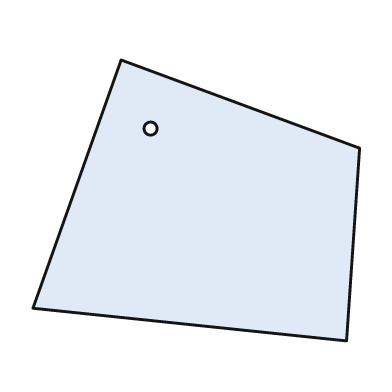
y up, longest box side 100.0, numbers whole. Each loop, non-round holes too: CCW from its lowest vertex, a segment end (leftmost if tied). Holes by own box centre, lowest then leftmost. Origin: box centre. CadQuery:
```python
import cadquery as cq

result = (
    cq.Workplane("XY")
    .moveTo(46.0, -43.0)
    .lineTo(50.0, 16.0)
    .lineTo(-23.0, 43.0)
    .lineTo(-50.0, -33.0)
    .close()
    .moveTo(-14.0, 22.0)
    .circle(2.0)
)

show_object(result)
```